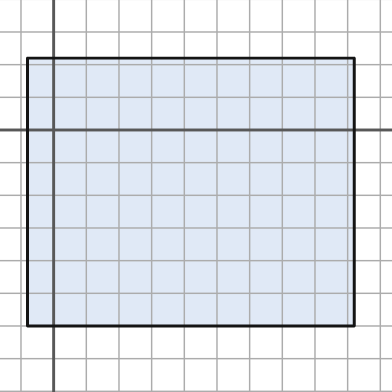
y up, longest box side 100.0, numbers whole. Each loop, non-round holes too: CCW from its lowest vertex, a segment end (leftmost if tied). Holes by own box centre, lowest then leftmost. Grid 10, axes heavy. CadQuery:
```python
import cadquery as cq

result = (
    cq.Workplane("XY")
    .moveTo(-8.0, -60.0)
    .lineTo(92.0, -60.0)
    .lineTo(92.0, 22.0)
    .lineTo(-8.0, 22.0)
    .close()
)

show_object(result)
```